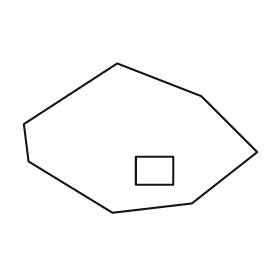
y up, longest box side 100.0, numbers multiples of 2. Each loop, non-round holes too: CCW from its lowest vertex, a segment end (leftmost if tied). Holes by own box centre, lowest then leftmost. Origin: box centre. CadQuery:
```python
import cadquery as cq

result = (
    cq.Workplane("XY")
    .moveTo(-12.0, -32.0)
    .lineTo(22.0, -28.0)
    .lineTo(50.0, -6.0)
    .lineTo(26.0, 18.0)
    .lineTo(-10.0, 32.0)
    .lineTo(-50.0, 6.0)
    .lineTo(-48.0, -10.0)
    .close()
    .moveTo(-2.0, -20.0)
    .lineTo(14.0, -20.0)
    .lineTo(14.0, -8.0)
    .lineTo(-2.0, -8.0)
    .close()
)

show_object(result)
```